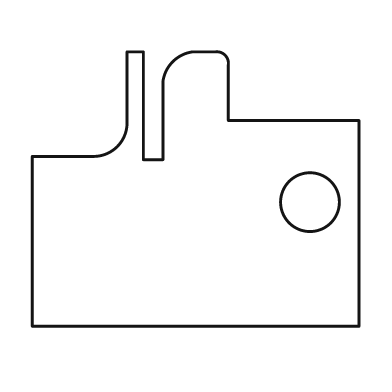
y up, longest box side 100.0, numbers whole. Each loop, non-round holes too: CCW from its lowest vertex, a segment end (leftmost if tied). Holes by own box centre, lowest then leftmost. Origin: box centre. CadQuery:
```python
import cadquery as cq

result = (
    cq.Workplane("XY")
    .moveTo(-50.0, -42.0)
    .lineTo(50.0, -42.0)
    .lineTo(50.0, 21.0)
    .lineTo(10.0, 21.0)
    .lineTo(10.0, 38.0)
    .threePointArc((9.0, 41.0), (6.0, 42.0))
    .lineTo(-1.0, 42.0)
    .threePointArc((-7.0, 39.0), (-10.0, 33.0))
    .lineTo(-10.0, 9.0)
    .lineTo(-16.0, 9.0)
    .lineTo(-16.0, 42.0)
    .lineTo(-21.0, 42.0)
    .lineTo(-21.0, 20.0)
    .threePointArc((-24.0, 13.0), (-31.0, 10.0))
    .lineTo(-50.0, 10.0)
    .close()
    .moveTo(35.0, -4.0)
    .circle(9.0)
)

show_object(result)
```